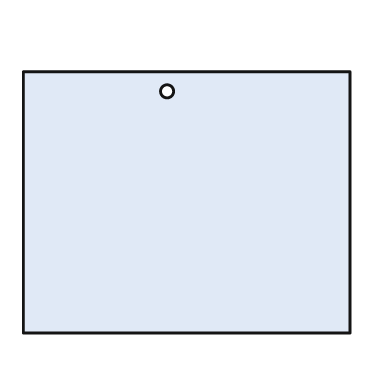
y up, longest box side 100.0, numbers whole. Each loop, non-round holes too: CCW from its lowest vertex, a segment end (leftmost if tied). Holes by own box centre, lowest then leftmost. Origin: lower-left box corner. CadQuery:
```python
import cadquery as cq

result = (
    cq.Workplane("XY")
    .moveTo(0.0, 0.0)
    .lineTo(100.0, 0.0)
    .lineTo(100.0, 80.0)
    .lineTo(0.0, 80.0)
    .close()
    .moveTo(44.0, 74.0)
    .circle(2.0)
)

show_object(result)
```